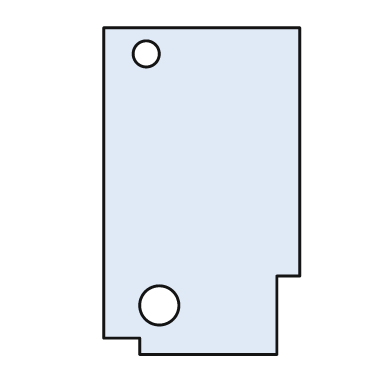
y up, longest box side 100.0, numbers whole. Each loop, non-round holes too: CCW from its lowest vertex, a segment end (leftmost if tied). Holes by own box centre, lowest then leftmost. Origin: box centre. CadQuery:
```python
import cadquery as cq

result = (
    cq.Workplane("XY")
    .moveTo(-19.0, -50.0)
    .lineTo(23.0, -50.0)
    .lineTo(23.0, -26.0)
    .lineTo(30.0, -26.0)
    .lineTo(30.0, 50.0)
    .lineTo(-30.0, 50.0)
    .lineTo(-30.0, -45.0)
    .lineTo(-19.0, -45.0)
    .close()
    .moveTo(-13.0, -35.0)
    .circle(6.0)
    .moveTo(-17.0, 42.0)
    .circle(4.0)
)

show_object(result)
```